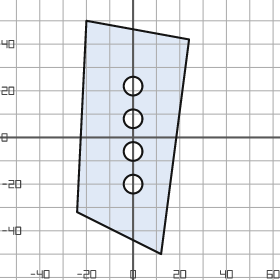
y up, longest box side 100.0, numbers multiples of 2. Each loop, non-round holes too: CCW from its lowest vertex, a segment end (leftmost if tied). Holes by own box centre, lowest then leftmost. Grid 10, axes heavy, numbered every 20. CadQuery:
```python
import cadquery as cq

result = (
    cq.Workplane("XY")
    .moveTo(12.0, -50.0)
    .lineTo(24.0, 42.0)
    .lineTo(-20.0, 50.0)
    .lineTo(-24.0, -32.0)
    .close()
    .moveTo(0.0, -20.0)
    .circle(4.0)
    .moveTo(0.0, -6.0)
    .circle(4.0)
    .moveTo(0.0, 8.0)
    .circle(4.0)
    .moveTo(0.0, 22.0)
    .circle(4.0)
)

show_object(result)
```